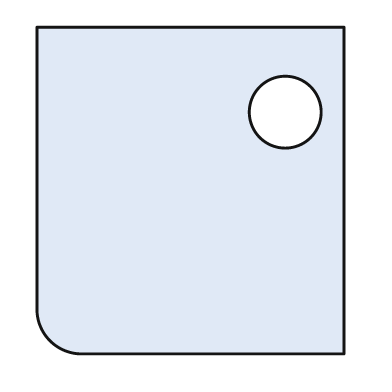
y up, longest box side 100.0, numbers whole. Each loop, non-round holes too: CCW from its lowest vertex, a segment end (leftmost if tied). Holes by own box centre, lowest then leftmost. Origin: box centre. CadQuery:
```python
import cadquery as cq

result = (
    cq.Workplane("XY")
    .moveTo(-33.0, -50.0)
    .lineTo(47.0, -50.0)
    .lineTo(47.0, 50.0)
    .lineTo(-47.0, 50.0)
    .lineTo(-47.0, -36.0)
    .threePointArc((-43.0, -46.0), (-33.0, -50.0))
    .close()
    .moveTo(29.0, 24.0)
    .circle(11.0)
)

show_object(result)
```